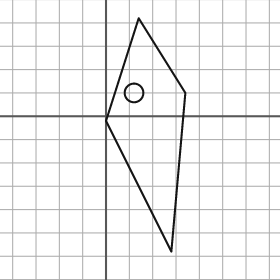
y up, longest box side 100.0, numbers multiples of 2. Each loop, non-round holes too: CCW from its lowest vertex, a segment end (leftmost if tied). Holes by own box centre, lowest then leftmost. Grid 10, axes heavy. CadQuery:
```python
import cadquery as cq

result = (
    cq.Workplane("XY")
    .moveTo(28.0, -58.0)
    .lineTo(34.0, 10.0)
    .lineTo(14.0, 42.0)
    .lineTo(0.0, -2.0)
    .close()
    .moveTo(12.0, 10.0)
    .circle(4.0)
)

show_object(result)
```